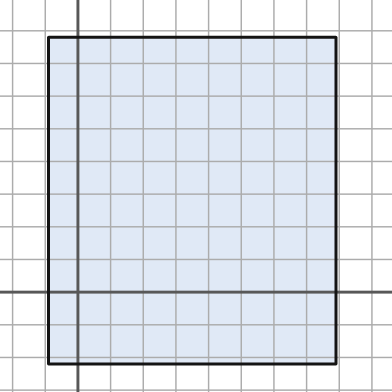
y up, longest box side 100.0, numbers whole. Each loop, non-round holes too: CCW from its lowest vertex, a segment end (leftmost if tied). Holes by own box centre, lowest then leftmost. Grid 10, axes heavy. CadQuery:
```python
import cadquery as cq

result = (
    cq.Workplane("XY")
    .moveTo(-9.0, -22.0)
    .lineTo(79.0, -22.0)
    .lineTo(79.0, 78.0)
    .lineTo(-9.0, 78.0)
    .close()
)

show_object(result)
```